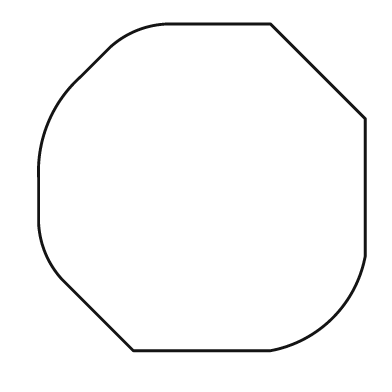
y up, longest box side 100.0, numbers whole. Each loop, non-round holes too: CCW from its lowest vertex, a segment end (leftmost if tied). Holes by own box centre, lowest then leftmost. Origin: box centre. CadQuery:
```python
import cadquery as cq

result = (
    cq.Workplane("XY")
    .moveTo(-21.0, -50.0)
    .lineTo(21.0, -50.0)
    .threePointArc((40.0, -40.0), (50.0, -21.0))
    .lineTo(50.0, 21.0)
    .lineTo(21.0, 50.0)
    .lineTo(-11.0, 50.0)
    .threePointArc((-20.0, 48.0), (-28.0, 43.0))
    .lineTo(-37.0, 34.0)
    .threePointArc((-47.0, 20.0), (-50.0, 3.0))
    .lineTo(-50.0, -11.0)
    .threePointArc((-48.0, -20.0), (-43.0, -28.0))
    .close()
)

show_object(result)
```